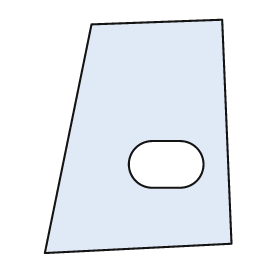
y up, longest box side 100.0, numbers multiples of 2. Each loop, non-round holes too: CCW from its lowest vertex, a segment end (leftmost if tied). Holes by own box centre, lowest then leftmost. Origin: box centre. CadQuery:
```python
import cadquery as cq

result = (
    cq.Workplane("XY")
    .moveTo(-40.0, -50.0)
    .lineTo(40.0, -46.0)
    .lineTo(36.0, 50.0)
    .lineTo(-20.0, 48.0)
    .close()
    .moveTo(6.0, -22.0)
    .lineTo(18.0, -22.0)
    .threePointArc((28.0, -12.0), (18.0, -2.0))
    .lineTo(6.0, -2.0)
    .threePointArc((-4.0, -12.0), (6.0, -22.0))
    .close()
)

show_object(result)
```